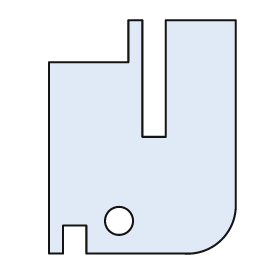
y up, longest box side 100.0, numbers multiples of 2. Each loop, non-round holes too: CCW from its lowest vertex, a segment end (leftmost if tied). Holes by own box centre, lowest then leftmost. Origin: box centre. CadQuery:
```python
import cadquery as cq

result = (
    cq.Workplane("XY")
    .moveTo(-40.0, -50.0)
    .lineTo(-34.0, -50.0)
    .lineTo(-34.0, -38.0)
    .lineTo(-24.0, -38.0)
    .lineTo(-24.0, -50.0)
    .lineTo(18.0, -50.0)
    .threePointArc((34.0, -44.0), (40.0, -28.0))
    .lineTo(40.0, 50.0)
    .lineTo(10.0, 50.0)
    .lineTo(10.0, 0.0)
    .lineTo(0.0, 0.0)
    .lineTo(0.0, 50.0)
    .lineTo(-6.0, 50.0)
    .lineTo(-6.0, 32.0)
    .lineTo(-40.0, 32.0)
    .close()
    .moveTo(-10.0, -36.0)
    .circle(6.0)
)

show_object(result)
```